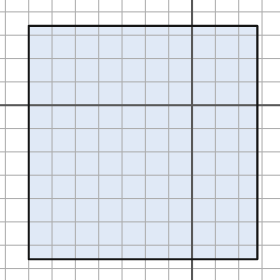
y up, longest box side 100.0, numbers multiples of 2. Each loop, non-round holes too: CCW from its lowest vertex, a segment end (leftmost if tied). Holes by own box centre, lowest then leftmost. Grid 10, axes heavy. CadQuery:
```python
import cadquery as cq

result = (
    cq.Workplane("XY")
    .moveTo(-70.0, -66.0)
    .lineTo(28.0, -66.0)
    .lineTo(28.0, 34.0)
    .lineTo(-70.0, 34.0)
    .close()
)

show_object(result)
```